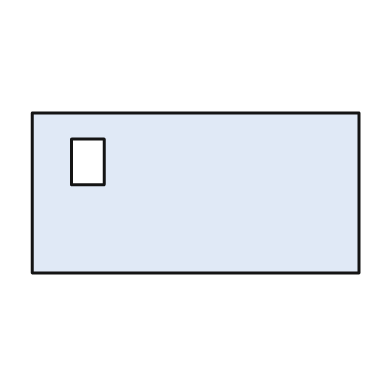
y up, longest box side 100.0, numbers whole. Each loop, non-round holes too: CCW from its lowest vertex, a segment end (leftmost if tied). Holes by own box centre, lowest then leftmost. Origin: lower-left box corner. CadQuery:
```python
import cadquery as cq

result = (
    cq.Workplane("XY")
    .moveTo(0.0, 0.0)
    .lineTo(100.0, 0.0)
    .lineTo(100.0, 49.0)
    .lineTo(0.0, 49.0)
    .close()
    .moveTo(12.0, 27.0)
    .lineTo(22.0, 27.0)
    .lineTo(22.0, 41.0)
    .lineTo(12.0, 41.0)
    .close()
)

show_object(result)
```